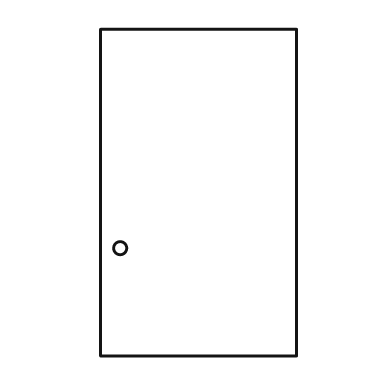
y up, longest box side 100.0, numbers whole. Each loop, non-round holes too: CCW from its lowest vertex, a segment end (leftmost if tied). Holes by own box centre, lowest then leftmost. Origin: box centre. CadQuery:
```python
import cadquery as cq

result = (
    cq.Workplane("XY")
    .moveTo(-30.0, -50.0)
    .lineTo(30.0, -50.0)
    .lineTo(30.0, 50.0)
    .lineTo(-30.0, 50.0)
    .close()
    .moveTo(-24.0, -17.0)
    .circle(2.0)
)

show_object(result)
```